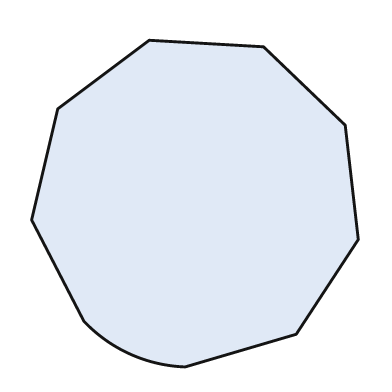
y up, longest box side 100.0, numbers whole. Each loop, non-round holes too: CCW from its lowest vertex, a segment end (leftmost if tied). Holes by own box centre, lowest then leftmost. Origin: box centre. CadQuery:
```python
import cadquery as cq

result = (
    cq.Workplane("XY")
    .moveTo(-3.0, -50.0)
    .lineTo(31.0, -40.0)
    .lineTo(50.0, -11.0)
    .lineTo(46.0, 24.0)
    .lineTo(21.0, 48.0)
    .lineTo(-14.0, 50.0)
    .lineTo(-42.0, 29.0)
    .lineTo(-50.0, -5.0)
    .lineTo(-34.0, -36.0)
    .threePointArc((-20.0, -46.0), (-3.0, -50.0))
    .close()
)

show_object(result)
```